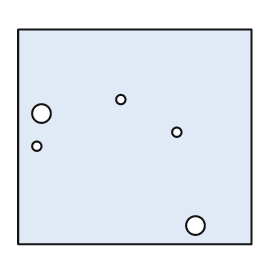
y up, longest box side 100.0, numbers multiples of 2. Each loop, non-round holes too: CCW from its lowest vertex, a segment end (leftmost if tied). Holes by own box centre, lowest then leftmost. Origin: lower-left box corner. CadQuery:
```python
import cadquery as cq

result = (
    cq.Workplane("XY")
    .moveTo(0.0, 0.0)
    .lineTo(100.0, 0.0)
    .lineTo(100.0, 92.0)
    .lineTo(0.0, 92.0)
    .close()
    .moveTo(76.0, 8.0)
    .circle(4.0)
    .moveTo(8.0, 42.0)
    .circle(2.0)
    .moveTo(68.0, 48.0)
    .circle(2.0)
    .moveTo(10.0, 56.0)
    .circle(4.0)
    .moveTo(44.0, 62.0)
    .circle(2.0)
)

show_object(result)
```